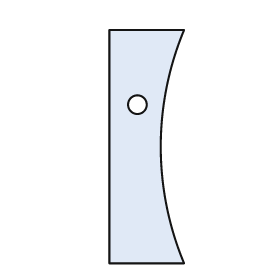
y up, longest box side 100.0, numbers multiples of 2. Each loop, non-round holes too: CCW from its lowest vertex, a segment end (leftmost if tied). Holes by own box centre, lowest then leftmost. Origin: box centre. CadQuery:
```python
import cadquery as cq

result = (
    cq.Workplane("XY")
    .moveTo(-16.0, -50.0)
    .lineTo(16.0, -50.0)
    .threePointArc((6.0, 0.0), (16.0, 50.0))
    .lineTo(-16.0, 50.0)
    .close()
    .moveTo(-4.0, 18.0)
    .circle(4.0)
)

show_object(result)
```